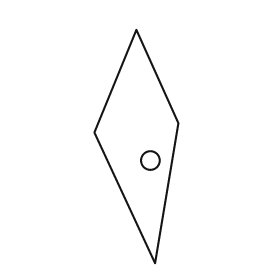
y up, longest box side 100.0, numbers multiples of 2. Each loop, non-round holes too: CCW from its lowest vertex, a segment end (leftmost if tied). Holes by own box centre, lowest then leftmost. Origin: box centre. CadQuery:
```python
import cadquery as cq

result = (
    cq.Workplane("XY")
    .moveTo(8.0, -50.0)
    .lineTo(18.0, 10.0)
    .lineTo(0.0, 50.0)
    .lineTo(-18.0, 6.0)
    .close()
    .moveTo(6.0, -6.0)
    .circle(4.0)
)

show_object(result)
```